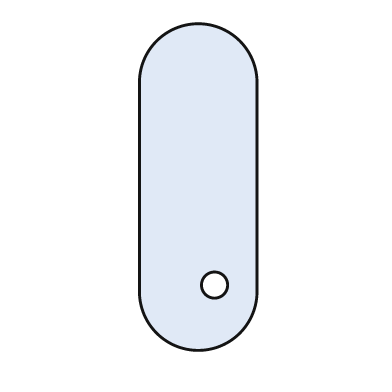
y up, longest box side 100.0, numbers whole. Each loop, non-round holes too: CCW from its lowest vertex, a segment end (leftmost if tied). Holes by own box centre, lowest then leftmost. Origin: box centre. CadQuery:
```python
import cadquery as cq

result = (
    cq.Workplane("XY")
    .moveTo(-18.0, -32.0)
    .threePointArc((0.0, -50.0), (18.0, -32.0))
    .lineTo(18.0, 32.0)
    .threePointArc((0.0, 50.0), (-18.0, 32.0))
    .close()
    .moveTo(5.0, -30.0)
    .circle(4.0)
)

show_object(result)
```